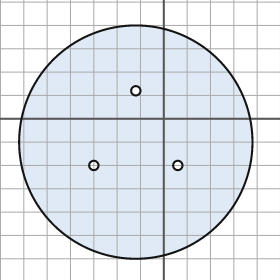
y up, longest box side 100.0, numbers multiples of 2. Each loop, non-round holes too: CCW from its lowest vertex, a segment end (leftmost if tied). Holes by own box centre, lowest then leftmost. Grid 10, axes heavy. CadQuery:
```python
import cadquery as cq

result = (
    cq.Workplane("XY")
    .moveTo(-12.0, -10.0)
    .circle(50.0)
    .moveTo(-30.0, -20.0)
    .circle(2.0)
    .moveTo(6.0, -20.0)
    .circle(2.0)
    .moveTo(-12.0, 12.0)
    .circle(2.0)
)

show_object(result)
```